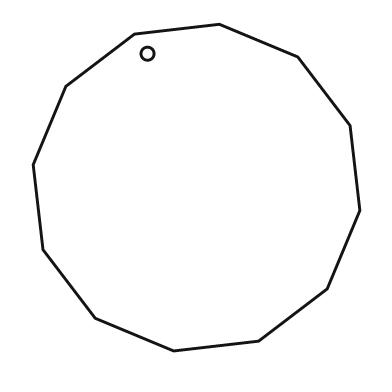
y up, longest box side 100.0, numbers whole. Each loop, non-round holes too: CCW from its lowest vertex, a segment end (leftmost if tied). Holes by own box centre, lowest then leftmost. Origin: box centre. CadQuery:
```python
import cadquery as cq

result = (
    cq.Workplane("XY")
    .moveTo(-7.0, -50.0)
    .lineTo(19.0, -47.0)
    .lineTo(40.0, -31.0)
    .lineTo(50.0, -7.0)
    .lineTo(47.0, 19.0)
    .lineTo(31.0, 40.0)
    .lineTo(7.0, 50.0)
    .lineTo(-19.0, 47.0)
    .lineTo(-40.0, 31.0)
    .lineTo(-50.0, 7.0)
    .lineTo(-47.0, -19.0)
    .lineTo(-31.0, -40.0)
    .close()
    .moveTo(-15.0, 41.0)
    .circle(2.0)
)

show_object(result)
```